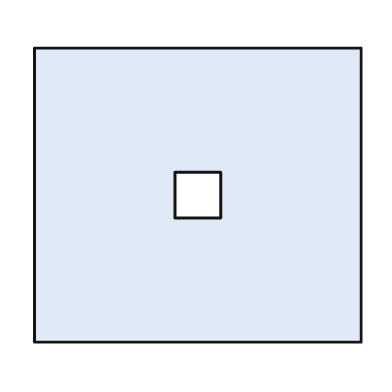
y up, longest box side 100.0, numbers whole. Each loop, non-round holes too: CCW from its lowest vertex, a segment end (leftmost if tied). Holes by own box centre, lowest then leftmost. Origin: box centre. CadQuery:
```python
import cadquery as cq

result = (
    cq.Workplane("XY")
    .moveTo(-50.0, -45.0)
    .lineTo(50.0, -45.0)
    .lineTo(50.0, 45.0)
    .lineTo(-50.0, 45.0)
    .close()
    .moveTo(-7.0, -7.0)
    .lineTo(7.0, -7.0)
    .lineTo(7.0, 7.0)
    .lineTo(-7.0, 7.0)
    .close()
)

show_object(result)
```